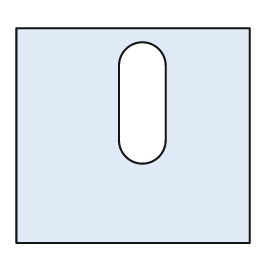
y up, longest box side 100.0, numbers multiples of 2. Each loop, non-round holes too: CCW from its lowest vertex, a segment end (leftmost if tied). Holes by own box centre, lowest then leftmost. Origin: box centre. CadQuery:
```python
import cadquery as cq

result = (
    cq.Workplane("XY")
    .moveTo(-50.0, -46.0)
    .lineTo(50.0, -46.0)
    .lineTo(50.0, 46.0)
    .lineTo(-50.0, 46.0)
    .close()
    .moveTo(-6.0, -2.0)
    .threePointArc((4.0, -12.0), (14.0, -2.0))
    .lineTo(14.0, 30.0)
    .threePointArc((4.0, 40.0), (-6.0, 30.0))
    .close()
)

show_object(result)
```